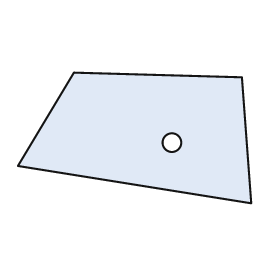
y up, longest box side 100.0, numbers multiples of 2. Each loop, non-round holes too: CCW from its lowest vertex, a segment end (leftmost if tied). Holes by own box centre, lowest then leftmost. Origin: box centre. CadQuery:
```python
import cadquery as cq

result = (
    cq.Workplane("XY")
    .moveTo(50.0, -28.0)
    .lineTo(46.0, 26.0)
    .lineTo(-26.0, 28.0)
    .lineTo(-50.0, -12.0)
    .close()
    .moveTo(16.0, -2.0)
    .circle(4.0)
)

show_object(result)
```